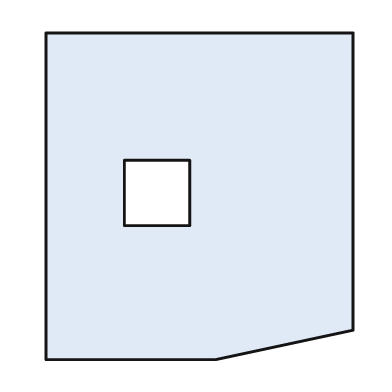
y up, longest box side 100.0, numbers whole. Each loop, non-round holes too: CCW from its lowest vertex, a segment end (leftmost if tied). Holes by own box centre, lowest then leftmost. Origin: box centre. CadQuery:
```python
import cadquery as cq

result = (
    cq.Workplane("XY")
    .moveTo(-47.0, -50.0)
    .lineTo(5.0, -50.0)
    .lineTo(47.0, -41.0)
    .lineTo(47.0, 50.0)
    .lineTo(-47.0, 50.0)
    .close()
    .moveTo(-23.0, -9.0)
    .lineTo(-3.0, -9.0)
    .lineTo(-3.0, 11.0)
    .lineTo(-23.0, 11.0)
    .close()
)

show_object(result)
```